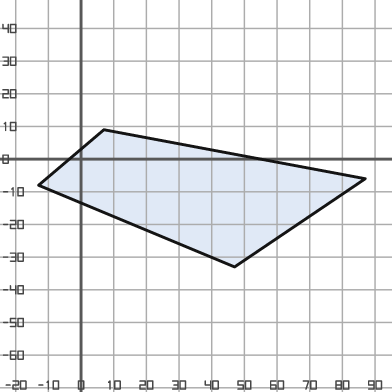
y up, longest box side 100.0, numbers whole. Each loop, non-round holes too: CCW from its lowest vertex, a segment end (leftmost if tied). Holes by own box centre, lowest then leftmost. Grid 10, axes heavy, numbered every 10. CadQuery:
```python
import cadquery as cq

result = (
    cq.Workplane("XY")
    .moveTo(47.0, -33.0)
    .lineTo(87.0, -6.0)
    .lineTo(7.0, 9.0)
    .lineTo(-13.0, -8.0)
    .close()
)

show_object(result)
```